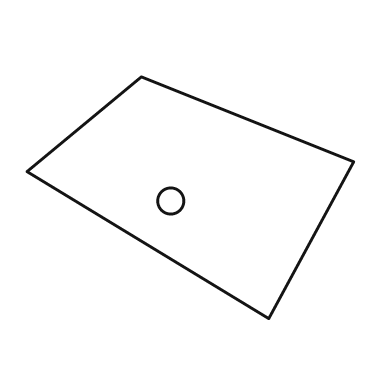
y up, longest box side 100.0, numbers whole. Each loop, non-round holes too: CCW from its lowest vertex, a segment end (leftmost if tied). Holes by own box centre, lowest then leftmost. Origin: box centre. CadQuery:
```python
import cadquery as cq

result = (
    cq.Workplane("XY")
    .moveTo(24.0, -37.0)
    .lineTo(50.0, 11.0)
    .lineTo(-15.0, 37.0)
    .lineTo(-50.0, 8.0)
    .close()
    .moveTo(-6.0, -1.0)
    .circle(4.0)
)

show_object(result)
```